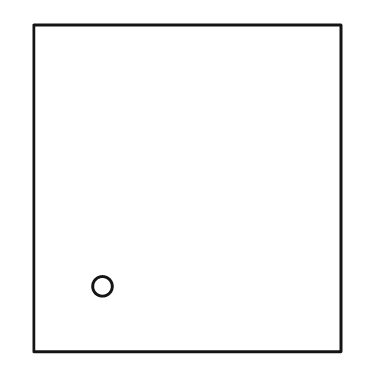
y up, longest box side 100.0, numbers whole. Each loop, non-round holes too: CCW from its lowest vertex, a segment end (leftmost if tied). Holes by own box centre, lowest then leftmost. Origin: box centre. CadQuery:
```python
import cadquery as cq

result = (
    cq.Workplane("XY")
    .moveTo(-47.0, -50.0)
    .lineTo(47.0, -50.0)
    .lineTo(47.0, 50.0)
    .lineTo(-47.0, 50.0)
    .close()
    .moveTo(-26.0, -30.0)
    .circle(3.0)
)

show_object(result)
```